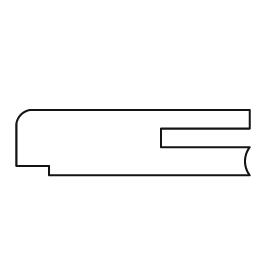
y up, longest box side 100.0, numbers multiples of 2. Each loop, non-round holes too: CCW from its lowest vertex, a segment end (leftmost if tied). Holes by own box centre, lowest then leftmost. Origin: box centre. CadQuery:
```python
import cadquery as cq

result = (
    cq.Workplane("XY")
    .moveTo(-36.0, -14.0)
    .lineTo(50.0, -14.0)
    .threePointArc((48.0, -8.0), (50.0, -2.0))
    .lineTo(12.0, -2.0)
    .lineTo(12.0, 6.0)
    .lineTo(50.0, 6.0)
    .lineTo(50.0, 14.0)
    .lineTo(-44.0, 14.0)
    .threePointArc((-48.0, 12.0), (-50.0, 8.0))
    .lineTo(-50.0, -10.0)
    .lineTo(-36.0, -10.0)
    .close()
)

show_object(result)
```